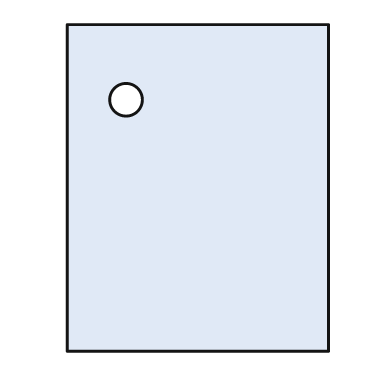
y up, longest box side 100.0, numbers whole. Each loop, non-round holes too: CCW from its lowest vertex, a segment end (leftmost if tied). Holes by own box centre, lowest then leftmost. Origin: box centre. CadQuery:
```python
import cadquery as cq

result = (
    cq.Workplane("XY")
    .moveTo(-40.0, -50.0)
    .lineTo(40.0, -50.0)
    .lineTo(40.0, 50.0)
    .lineTo(-40.0, 50.0)
    .close()
    .moveTo(-22.0, 27.0)
    .circle(5.0)
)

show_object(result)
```